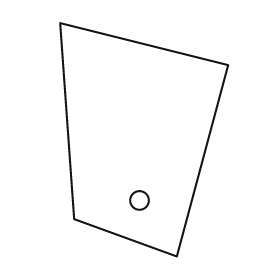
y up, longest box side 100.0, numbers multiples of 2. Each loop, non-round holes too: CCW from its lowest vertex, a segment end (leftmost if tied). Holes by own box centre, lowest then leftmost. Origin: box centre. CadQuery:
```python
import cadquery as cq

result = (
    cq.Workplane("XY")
    .moveTo(14.0, -50.0)
    .lineTo(36.0, 32.0)
    .lineTo(-36.0, 50.0)
    .lineTo(-30.0, -34.0)
    .close()
    .moveTo(-2.0, -26.0)
    .circle(4.0)
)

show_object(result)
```